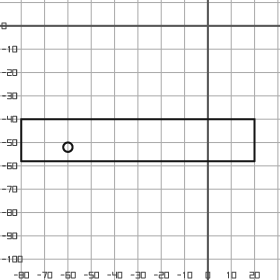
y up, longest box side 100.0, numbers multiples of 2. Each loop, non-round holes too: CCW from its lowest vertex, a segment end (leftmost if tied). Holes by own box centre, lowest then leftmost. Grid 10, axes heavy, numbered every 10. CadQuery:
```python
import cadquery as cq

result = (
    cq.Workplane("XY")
    .moveTo(-80.0, -58.0)
    .lineTo(20.0, -58.0)
    .lineTo(20.0, -40.0)
    .lineTo(-80.0, -40.0)
    .close()
    .moveTo(-60.0, -52.0)
    .circle(2.0)
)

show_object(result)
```